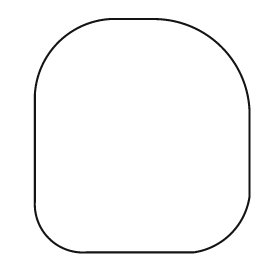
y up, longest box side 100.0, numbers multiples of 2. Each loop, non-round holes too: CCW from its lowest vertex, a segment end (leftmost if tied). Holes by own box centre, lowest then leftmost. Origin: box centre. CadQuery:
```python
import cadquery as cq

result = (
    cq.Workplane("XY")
    .moveTo(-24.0, -50.0)
    .lineTo(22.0, -50.0)
    .threePointArc((38.0, -42.0), (46.0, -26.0))
    .lineTo(46.0, 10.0)
    .threePointArc((34.0, 38.0), (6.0, 50.0))
    .lineTo(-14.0, 50.0)
    .threePointArc((-36.0, 40.0), (-46.0, 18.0))
    .lineTo(-46.0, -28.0)
    .threePointArc((-40.0, -44.0), (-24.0, -50.0))
    .close()
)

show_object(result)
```